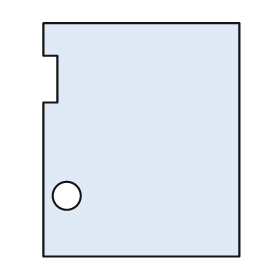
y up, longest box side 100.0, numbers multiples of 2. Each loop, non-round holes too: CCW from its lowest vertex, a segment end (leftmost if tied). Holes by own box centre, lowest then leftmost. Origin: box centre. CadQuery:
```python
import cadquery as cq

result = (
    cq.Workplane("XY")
    .moveTo(-42.0, -50.0)
    .lineTo(42.0, -50.0)
    .lineTo(42.0, 50.0)
    .lineTo(-42.0, 50.0)
    .lineTo(-42.0, 36.0)
    .lineTo(-36.0, 36.0)
    .lineTo(-36.0, 16.0)
    .lineTo(-42.0, 16.0)
    .close()
    .moveTo(-32.0, -24.0)
    .circle(6.0)
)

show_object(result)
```